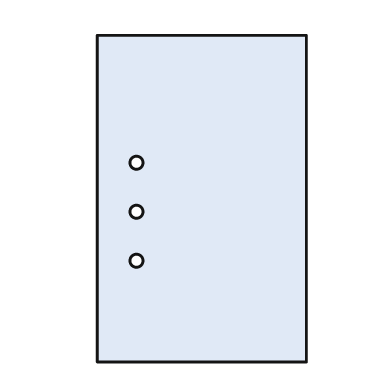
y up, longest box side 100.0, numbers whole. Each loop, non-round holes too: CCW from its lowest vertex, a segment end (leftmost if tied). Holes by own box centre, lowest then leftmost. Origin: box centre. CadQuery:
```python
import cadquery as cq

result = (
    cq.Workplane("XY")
    .moveTo(-32.0, -50.0)
    .lineTo(32.0, -50.0)
    .lineTo(32.0, 50.0)
    .lineTo(-32.0, 50.0)
    .close()
    .moveTo(-20.0, -19.0)
    .circle(2.0)
    .moveTo(-20.0, -4.0)
    .circle(2.0)
    .moveTo(-20.0, 11.0)
    .circle(2.0)
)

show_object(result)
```